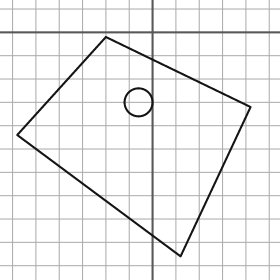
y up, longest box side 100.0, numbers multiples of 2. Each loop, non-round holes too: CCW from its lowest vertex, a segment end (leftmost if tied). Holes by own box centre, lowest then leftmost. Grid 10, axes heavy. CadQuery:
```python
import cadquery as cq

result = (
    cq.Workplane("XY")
    .moveTo(12.0, -96.0)
    .lineTo(42.0, -32.0)
    .lineTo(-20.0, -2.0)
    .lineTo(-58.0, -44.0)
    .close()
    .moveTo(-6.0, -30.0)
    .circle(6.0)
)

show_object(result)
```